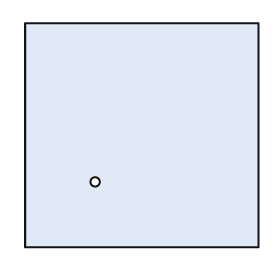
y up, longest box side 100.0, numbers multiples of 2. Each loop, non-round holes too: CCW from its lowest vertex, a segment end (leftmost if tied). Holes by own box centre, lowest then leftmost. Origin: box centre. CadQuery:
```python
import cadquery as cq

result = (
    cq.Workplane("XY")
    .moveTo(-50.0, -48.0)
    .lineTo(50.0, -48.0)
    .lineTo(50.0, 48.0)
    .lineTo(-50.0, 48.0)
    .close()
    .moveTo(-20.0, -20.0)
    .circle(2.0)
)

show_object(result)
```